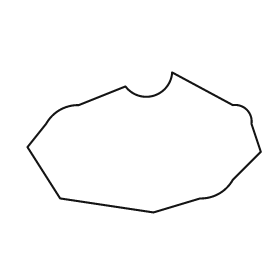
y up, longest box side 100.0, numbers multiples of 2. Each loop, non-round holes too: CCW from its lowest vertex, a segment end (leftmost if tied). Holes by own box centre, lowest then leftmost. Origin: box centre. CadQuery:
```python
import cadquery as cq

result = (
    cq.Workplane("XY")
    .moveTo(4.0, -30.0)
    .lineTo(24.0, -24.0)
    .threePointArc((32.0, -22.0), (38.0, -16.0))
    .lineTo(50.0, -4.0)
    .lineTo(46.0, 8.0)
    .threePointArc((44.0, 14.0), (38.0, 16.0))
    .lineTo(12.0, 30.0)
    .threePointArc((4.0, 20.0), (-8.0, 24.0))
    .lineTo(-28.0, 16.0)
    .threePointArc((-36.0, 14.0), (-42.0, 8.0))
    .lineTo(-50.0, -2.0)
    .lineTo(-36.0, -24.0)
    .close()
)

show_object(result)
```